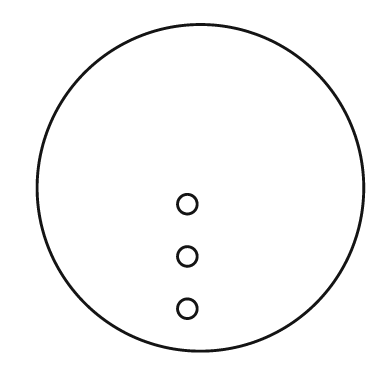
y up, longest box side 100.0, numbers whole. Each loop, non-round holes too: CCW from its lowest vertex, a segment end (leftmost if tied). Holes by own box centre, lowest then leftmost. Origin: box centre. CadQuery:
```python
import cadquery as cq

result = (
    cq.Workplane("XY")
    .moveTo(0.0, 0.0)
    .circle(50.0)
    .moveTo(-4.0, -37.0)
    .circle(3.0)
    .moveTo(-4.0, -21.0)
    .circle(3.0)
    .moveTo(-4.0, -5.0)
    .circle(3.0)
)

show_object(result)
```